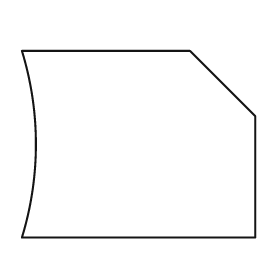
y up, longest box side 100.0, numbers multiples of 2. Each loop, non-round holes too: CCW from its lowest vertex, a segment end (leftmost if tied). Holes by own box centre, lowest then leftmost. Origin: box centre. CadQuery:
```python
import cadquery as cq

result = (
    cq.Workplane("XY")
    .moveTo(-50.0, -40.0)
    .lineTo(50.0, -40.0)
    .lineTo(50.0, 12.0)
    .lineTo(22.0, 40.0)
    .lineTo(-50.0, 40.0)
    .threePointArc((-44.0, 0.0), (-50.0, -40.0))
    .close()
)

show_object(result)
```